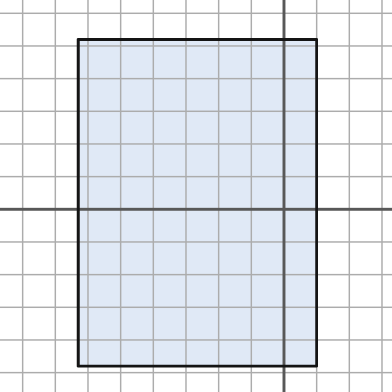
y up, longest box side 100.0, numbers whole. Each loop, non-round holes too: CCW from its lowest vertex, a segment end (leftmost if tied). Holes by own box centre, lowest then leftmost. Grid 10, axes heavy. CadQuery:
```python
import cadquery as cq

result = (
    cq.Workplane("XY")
    .moveTo(-63.0, -48.0)
    .lineTo(10.0, -48.0)
    .lineTo(10.0, 52.0)
    .lineTo(-63.0, 52.0)
    .close()
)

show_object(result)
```